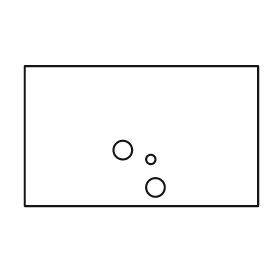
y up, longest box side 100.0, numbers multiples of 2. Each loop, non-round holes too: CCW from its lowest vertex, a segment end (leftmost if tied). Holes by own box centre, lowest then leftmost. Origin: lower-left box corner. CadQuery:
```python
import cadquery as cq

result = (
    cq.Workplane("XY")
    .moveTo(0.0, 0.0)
    .lineTo(100.0, 0.0)
    .lineTo(100.0, 60.0)
    .lineTo(0.0, 60.0)
    .close()
    .moveTo(56.0, 8.0)
    .circle(4.0)
    .moveTo(54.0, 20.0)
    .circle(2.0)
    .moveTo(42.0, 24.0)
    .circle(4.0)
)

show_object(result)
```